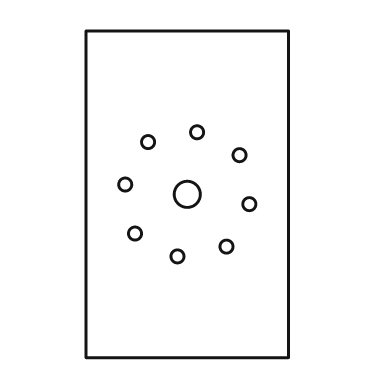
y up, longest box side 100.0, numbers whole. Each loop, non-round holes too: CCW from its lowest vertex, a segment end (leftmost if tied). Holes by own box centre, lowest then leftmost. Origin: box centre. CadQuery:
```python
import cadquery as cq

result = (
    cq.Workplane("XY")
    .moveTo(-31.0, -50.0)
    .lineTo(31.0, -50.0)
    .lineTo(31.0, 50.0)
    .lineTo(-31.0, 50.0)
    .close()
    .moveTo(-3.0, -19.0)
    .circle(2.0)
    .moveTo(12.0, -16.0)
    .circle(2.0)
    .moveTo(-16.0, -12.0)
    .circle(2.0)
    .moveTo(19.0, -3.0)
    .circle(2.0)
    .moveTo(0.0, 0.0)
    .circle(4.0)
    .moveTo(-19.0, 3.0)
    .circle(2.0)
    .moveTo(16.0, 12.0)
    .circle(2.0)
    .moveTo(-12.0, 16.0)
    .circle(2.0)
    .moveTo(3.0, 19.0)
    .circle(2.0)
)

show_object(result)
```